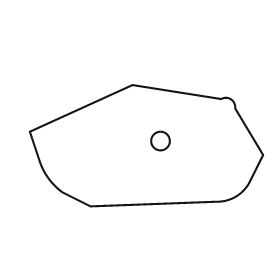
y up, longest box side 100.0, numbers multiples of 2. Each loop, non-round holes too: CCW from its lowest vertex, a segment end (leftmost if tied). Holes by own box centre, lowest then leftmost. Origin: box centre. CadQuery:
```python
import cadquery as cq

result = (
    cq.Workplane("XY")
    .moveTo(-24.0, -26.0)
    .lineTo(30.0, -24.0)
    .threePointArc((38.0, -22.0), (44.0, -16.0))
    .lineTo(50.0, -4.0)
    .lineTo(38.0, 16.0)
    .threePointArc((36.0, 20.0), (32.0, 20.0))
    .lineTo(-6.0, 26.0)
    .lineTo(-50.0, 6.0)
    .lineTo(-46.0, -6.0)
    .threePointArc((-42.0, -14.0), (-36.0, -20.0))
    .close()
    .moveTo(6.0, 2.0)
    .circle(4.0)
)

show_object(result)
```